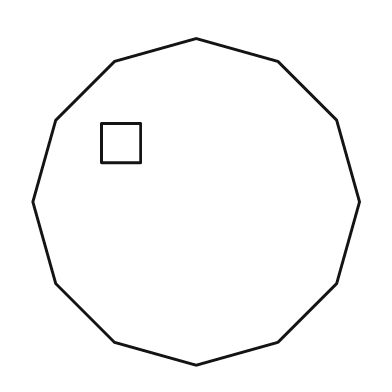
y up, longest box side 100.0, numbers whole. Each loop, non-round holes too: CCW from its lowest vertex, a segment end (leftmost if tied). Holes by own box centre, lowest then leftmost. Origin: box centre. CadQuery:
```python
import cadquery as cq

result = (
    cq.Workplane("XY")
    .moveTo(0.0, -50.0)
    .lineTo(25.0, -43.0)
    .lineTo(43.0, -25.0)
    .lineTo(50.0, 0.0)
    .lineTo(43.0, 25.0)
    .lineTo(25.0, 43.0)
    .lineTo(0.0, 50.0)
    .lineTo(-25.0, 43.0)
    .lineTo(-43.0, 25.0)
    .lineTo(-50.0, 0.0)
    .lineTo(-43.0, -25.0)
    .lineTo(-25.0, -43.0)
    .close()
    .moveTo(-29.0, 12.0)
    .lineTo(-17.0, 12.0)
    .lineTo(-17.0, 24.0)
    .lineTo(-29.0, 24.0)
    .close()
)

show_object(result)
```